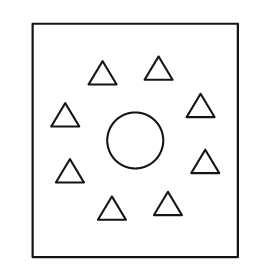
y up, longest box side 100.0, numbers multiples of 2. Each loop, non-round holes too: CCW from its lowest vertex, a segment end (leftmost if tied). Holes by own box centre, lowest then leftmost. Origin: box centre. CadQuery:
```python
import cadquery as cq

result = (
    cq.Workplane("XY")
    .moveTo(-44.0, -50.0)
    .lineTo(44.0, -50.0)
    .lineTo(44.0, 50.0)
    .lineTo(-44.0, 50.0)
    .close()
    .moveTo(-16.0, -34.0)
    .lineTo(-4.0, -34.0)
    .lineTo(-10.0, -24.0)
    .close()
    .moveTo(8.0, -32.0)
    .lineTo(20.0, -32.0)
    .lineTo(14.0, -22.0)
    .close()
    .moveTo(-34.0, -18.0)
    .lineTo(-22.0, -18.0)
    .lineTo(-28.0, -8.0)
    .close()
    .moveTo(24.0, -14.0)
    .lineTo(36.0, -14.0)
    .lineTo(30.0, -4.0)
    .close()
    .moveTo(0.0, 0.0)
    .circle(12.0)
    .moveTo(-36.0, 6.0)
    .lineTo(-24.0, 6.0)
    .lineTo(-30.0, 16.0)
    .close()
    .moveTo(22.0, 10.0)
    .lineTo(34.0, 10.0)
    .lineTo(28.0, 20.0)
    .close()
    .moveTo(-20.0, 24.0)
    .lineTo(-8.0, 24.0)
    .lineTo(-14.0, 34.0)
    .close()
    .moveTo(4.0, 26.0)
    .lineTo(16.0, 26.0)
    .lineTo(10.0, 36.0)
    .close()
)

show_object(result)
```